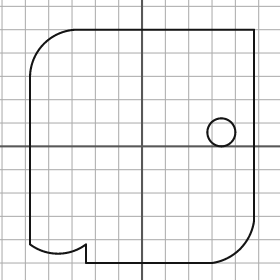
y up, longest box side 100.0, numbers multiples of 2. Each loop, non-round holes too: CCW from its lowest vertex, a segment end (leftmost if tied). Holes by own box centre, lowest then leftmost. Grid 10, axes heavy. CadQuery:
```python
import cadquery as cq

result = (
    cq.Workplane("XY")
    .moveTo(-24.0, -50.0)
    .lineTo(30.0, -50.0)
    .threePointArc((42.0, -44.0), (48.0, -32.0))
    .lineTo(48.0, 50.0)
    .lineTo(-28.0, 50.0)
    .threePointArc((-42.0, 44.0), (-48.0, 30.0))
    .lineTo(-48.0, -42.0)
    .threePointArc((-36.0, -46.0), (-24.0, -42.0))
    .close()
    .moveTo(34.0, 6.0)
    .circle(6.0)
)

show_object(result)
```